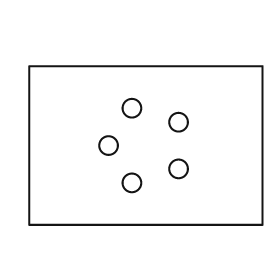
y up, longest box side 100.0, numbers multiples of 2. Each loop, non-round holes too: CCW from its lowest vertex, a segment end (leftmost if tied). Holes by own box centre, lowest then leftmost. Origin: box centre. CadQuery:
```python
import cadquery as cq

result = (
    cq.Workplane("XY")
    .moveTo(-50.0, -34.0)
    .lineTo(50.0, -34.0)
    .lineTo(50.0, 34.0)
    .lineTo(-50.0, 34.0)
    .close()
    .moveTo(-6.0, -16.0)
    .circle(4.0)
    .moveTo(14.0, -10.0)
    .circle(4.0)
    .moveTo(-16.0, 0.0)
    .circle(4.0)
    .moveTo(14.0, 10.0)
    .circle(4.0)
    .moveTo(-6.0, 16.0)
    .circle(4.0)
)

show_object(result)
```